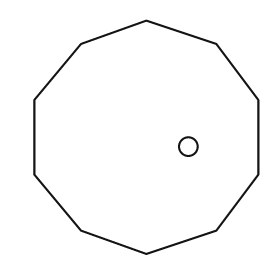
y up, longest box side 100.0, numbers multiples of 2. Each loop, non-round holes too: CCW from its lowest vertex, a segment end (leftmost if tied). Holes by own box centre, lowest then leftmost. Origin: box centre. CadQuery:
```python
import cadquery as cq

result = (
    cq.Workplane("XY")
    .moveTo(0.0, -50.0)
    .lineTo(30.0, -40.0)
    .lineTo(48.0, -16.0)
    .lineTo(48.0, 16.0)
    .lineTo(30.0, 40.0)
    .lineTo(0.0, 50.0)
    .lineTo(-28.0, 40.0)
    .lineTo(-48.0, 16.0)
    .lineTo(-48.0, -16.0)
    .lineTo(-28.0, -40.0)
    .close()
    .moveTo(18.0, -4.0)
    .circle(4.0)
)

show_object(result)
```